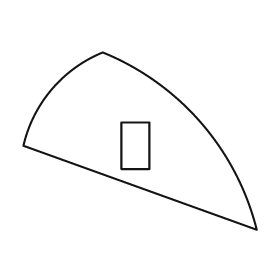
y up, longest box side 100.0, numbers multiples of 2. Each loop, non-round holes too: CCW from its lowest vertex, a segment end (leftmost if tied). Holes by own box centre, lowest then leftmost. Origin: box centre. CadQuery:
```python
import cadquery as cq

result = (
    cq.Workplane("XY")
    .moveTo(50.0, -38.0)
    .threePointArc((26.0, 8.0), (-16.0, 38.0))
    .threePointArc((-38.0, 22.0), (-50.0, -2.0))
    .close()
    .moveTo(-8.0, -12.0)
    .lineTo(4.0, -12.0)
    .lineTo(4.0, 8.0)
    .lineTo(-8.0, 8.0)
    .close()
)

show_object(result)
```